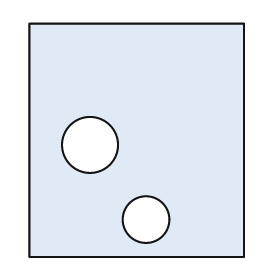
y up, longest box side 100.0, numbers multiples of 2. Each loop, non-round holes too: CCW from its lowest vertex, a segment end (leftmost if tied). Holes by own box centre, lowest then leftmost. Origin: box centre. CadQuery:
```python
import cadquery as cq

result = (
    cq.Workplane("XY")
    .moveTo(-46.0, -50.0)
    .lineTo(46.0, -50.0)
    .lineTo(46.0, 50.0)
    .lineTo(-46.0, 50.0)
    .close()
    .moveTo(4.0, -34.0)
    .circle(10.0)
    .moveTo(-20.0, -2.0)
    .circle(12.0)
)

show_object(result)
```